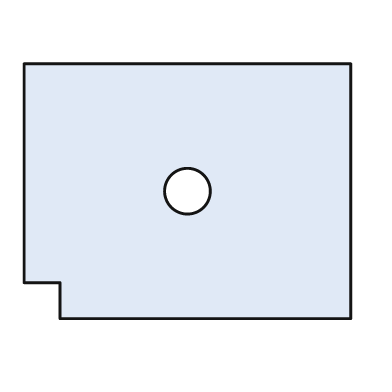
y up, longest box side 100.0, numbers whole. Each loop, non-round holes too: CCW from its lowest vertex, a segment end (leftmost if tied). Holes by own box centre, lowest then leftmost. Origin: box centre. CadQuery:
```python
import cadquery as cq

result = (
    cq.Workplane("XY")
    .moveTo(-39.0, -39.0)
    .lineTo(50.0, -39.0)
    .lineTo(50.0, 39.0)
    .lineTo(-50.0, 39.0)
    .lineTo(-50.0, -28.0)
    .lineTo(-39.0, -28.0)
    .close()
    .moveTo(0.0, 0.0)
    .circle(7.0)
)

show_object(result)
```